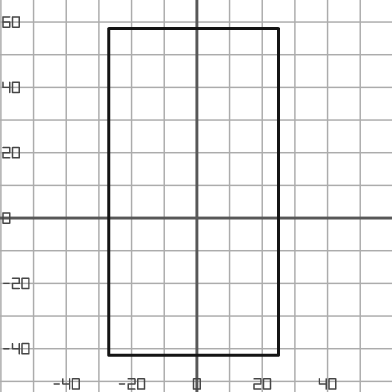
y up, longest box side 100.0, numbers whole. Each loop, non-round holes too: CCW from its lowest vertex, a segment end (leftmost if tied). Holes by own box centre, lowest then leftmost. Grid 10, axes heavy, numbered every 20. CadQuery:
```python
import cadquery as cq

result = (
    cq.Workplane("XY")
    .moveTo(-27.0, -42.0)
    .lineTo(25.0, -42.0)
    .lineTo(25.0, 58.0)
    .lineTo(-27.0, 58.0)
    .close()
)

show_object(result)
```